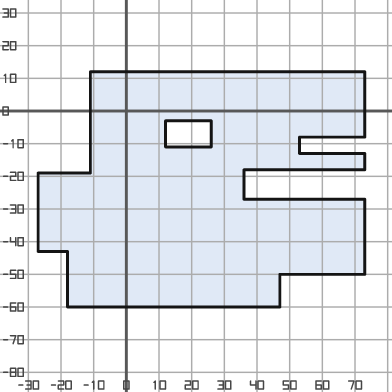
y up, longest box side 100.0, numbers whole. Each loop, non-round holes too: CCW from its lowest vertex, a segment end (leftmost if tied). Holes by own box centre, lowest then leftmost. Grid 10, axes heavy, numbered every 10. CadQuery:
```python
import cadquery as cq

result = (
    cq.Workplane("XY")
    .moveTo(-18.0, -60.0)
    .lineTo(47.0, -60.0)
    .lineTo(47.0, -50.0)
    .lineTo(73.0, -50.0)
    .lineTo(73.0, -27.0)
    .lineTo(36.0, -27.0)
    .lineTo(36.0, -18.0)
    .lineTo(73.0, -18.0)
    .lineTo(73.0, -13.0)
    .lineTo(53.0, -13.0)
    .lineTo(53.0, -8.0)
    .lineTo(73.0, -8.0)
    .lineTo(73.0, 12.0)
    .lineTo(-11.0, 12.0)
    .lineTo(-11.0, -19.0)
    .lineTo(-27.0, -19.0)
    .lineTo(-27.0, -43.0)
    .lineTo(-18.0, -43.0)
    .close()
    .moveTo(12.0, -11.0)
    .lineTo(26.0, -11.0)
    .lineTo(26.0, -3.0)
    .lineTo(12.0, -3.0)
    .close()
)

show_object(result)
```